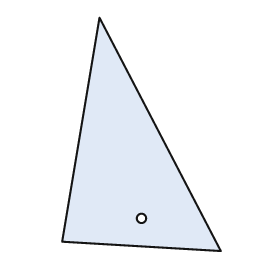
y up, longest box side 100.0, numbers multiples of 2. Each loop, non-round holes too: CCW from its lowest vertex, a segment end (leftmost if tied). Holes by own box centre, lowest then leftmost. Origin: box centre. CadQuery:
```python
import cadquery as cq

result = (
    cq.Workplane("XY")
    .moveTo(34.0, -50.0)
    .lineTo(-18.0, 50.0)
    .lineTo(-34.0, -46.0)
    .close()
    .moveTo(0.0, -36.0)
    .circle(2.0)
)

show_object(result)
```